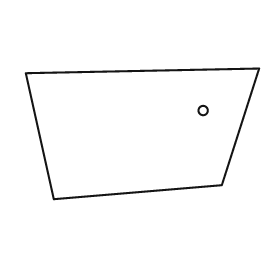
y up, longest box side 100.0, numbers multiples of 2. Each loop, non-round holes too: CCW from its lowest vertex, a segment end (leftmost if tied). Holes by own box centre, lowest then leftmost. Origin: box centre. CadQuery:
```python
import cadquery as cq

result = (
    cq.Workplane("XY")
    .moveTo(-38.0, -28.0)
    .lineTo(34.0, -22.0)
    .lineTo(50.0, 28.0)
    .lineTo(-50.0, 26.0)
    .close()
    .moveTo(26.0, 10.0)
    .circle(2.0)
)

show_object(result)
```